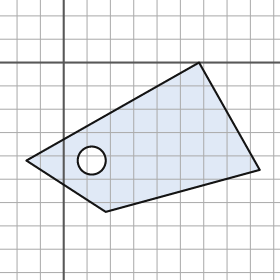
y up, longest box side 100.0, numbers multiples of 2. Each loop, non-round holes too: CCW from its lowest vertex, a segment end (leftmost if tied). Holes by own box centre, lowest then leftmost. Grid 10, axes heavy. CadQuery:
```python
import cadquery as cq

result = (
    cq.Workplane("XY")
    .moveTo(18.0, -64.0)
    .lineTo(84.0, -46.0)
    .lineTo(58.0, 0.0)
    .lineTo(-16.0, -42.0)
    .close()
    .moveTo(12.0, -42.0)
    .circle(6.0)
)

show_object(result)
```